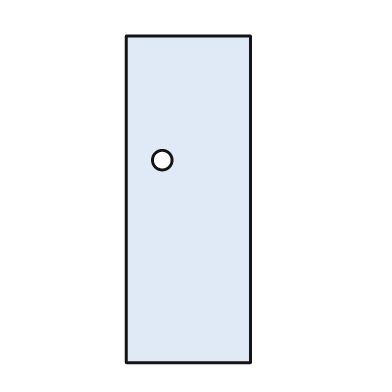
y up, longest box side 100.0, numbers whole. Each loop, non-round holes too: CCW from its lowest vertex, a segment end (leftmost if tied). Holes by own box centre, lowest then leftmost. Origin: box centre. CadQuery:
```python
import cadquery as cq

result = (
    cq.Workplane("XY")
    .moveTo(-19.0, -50.0)
    .lineTo(19.0, -50.0)
    .lineTo(19.0, 50.0)
    .lineTo(-19.0, 50.0)
    .close()
    .moveTo(-8.0, 12.0)
    .circle(3.0)
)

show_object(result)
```